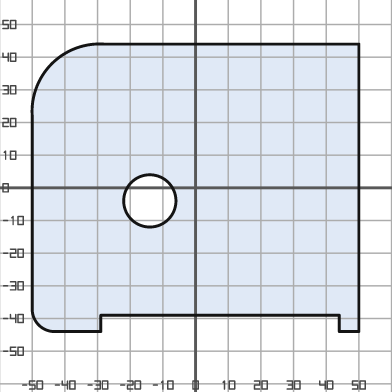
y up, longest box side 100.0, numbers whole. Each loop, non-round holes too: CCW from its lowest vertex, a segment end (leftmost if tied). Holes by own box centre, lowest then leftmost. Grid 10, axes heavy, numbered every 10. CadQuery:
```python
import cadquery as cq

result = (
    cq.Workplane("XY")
    .moveTo(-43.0, -44.0)
    .lineTo(-29.0, -44.0)
    .lineTo(-29.0, -39.0)
    .lineTo(44.0, -39.0)
    .lineTo(44.0, -44.0)
    .lineTo(50.0, -44.0)
    .lineTo(50.0, 44.0)
    .lineTo(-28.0, 44.0)
    .threePointArc((-44.0, 38.0), (-50.0, 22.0))
    .lineTo(-50.0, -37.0)
    .threePointArc((-48.0, -42.0), (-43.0, -44.0))
    .close()
    .moveTo(-14.0, -4.0)
    .circle(8.0)
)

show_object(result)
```